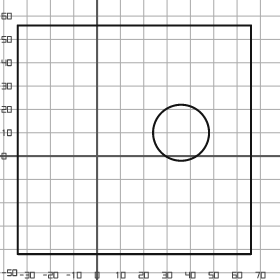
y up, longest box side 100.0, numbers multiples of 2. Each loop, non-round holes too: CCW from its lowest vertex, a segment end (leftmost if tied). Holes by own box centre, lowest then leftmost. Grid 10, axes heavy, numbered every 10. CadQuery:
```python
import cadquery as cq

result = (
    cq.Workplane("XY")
    .moveTo(-34.0, -42.0)
    .lineTo(66.0, -42.0)
    .lineTo(66.0, 56.0)
    .lineTo(-34.0, 56.0)
    .close()
    .moveTo(36.0, 10.0)
    .circle(12.0)
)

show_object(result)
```